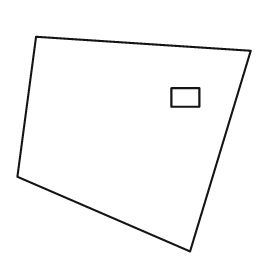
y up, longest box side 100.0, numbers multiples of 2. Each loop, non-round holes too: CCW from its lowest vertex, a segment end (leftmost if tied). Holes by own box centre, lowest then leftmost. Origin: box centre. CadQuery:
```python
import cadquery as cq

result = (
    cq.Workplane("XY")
    .moveTo(24.0, -46.0)
    .lineTo(50.0, 40.0)
    .lineTo(-42.0, 46.0)
    .lineTo(-50.0, -14.0)
    .close()
    .moveTo(16.0, 16.0)
    .lineTo(28.0, 16.0)
    .lineTo(28.0, 24.0)
    .lineTo(16.0, 24.0)
    .close()
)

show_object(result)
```